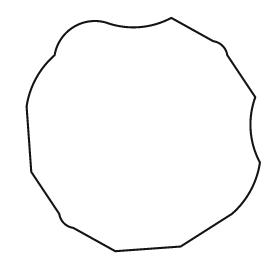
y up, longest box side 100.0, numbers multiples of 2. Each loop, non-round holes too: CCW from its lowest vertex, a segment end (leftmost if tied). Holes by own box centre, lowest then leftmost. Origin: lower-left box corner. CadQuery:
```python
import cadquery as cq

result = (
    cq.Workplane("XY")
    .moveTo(38.0, 0.0)
    .lineTo(66.0, 2.0)
    .lineTo(88.0, 16.0)
    .threePointArc((96.0, 26.0), (100.0, 38.0))
    .threePointArc((96.0, 52.0), (98.0, 66.0))
    .lineTo(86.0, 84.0)
    .threePointArc((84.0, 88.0), (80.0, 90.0))
    .lineTo(62.0, 100.0)
    .threePointArc((48.0, 96.0), (34.0, 98.0))
    .threePointArc((20.0, 96.0), (12.0, 84.0))
    .threePointArc((4.0, 74.0), (0.0, 62.0))
    .lineTo(2.0, 34.0)
    .lineTo(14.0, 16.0)
    .threePointArc((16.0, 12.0), (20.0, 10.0))
    .close()
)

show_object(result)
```